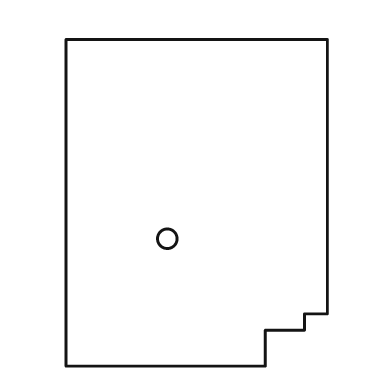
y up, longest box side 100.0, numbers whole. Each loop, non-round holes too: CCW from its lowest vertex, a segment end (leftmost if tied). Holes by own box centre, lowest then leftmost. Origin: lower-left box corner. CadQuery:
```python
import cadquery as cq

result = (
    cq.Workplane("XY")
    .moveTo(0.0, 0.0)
    .lineTo(61.0, 0.0)
    .lineTo(61.0, 11.0)
    .lineTo(73.0, 11.0)
    .lineTo(73.0, 16.0)
    .lineTo(80.0, 16.0)
    .lineTo(80.0, 100.0)
    .lineTo(0.0, 100.0)
    .close()
    .moveTo(31.0, 39.0)
    .circle(3.0)
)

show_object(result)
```